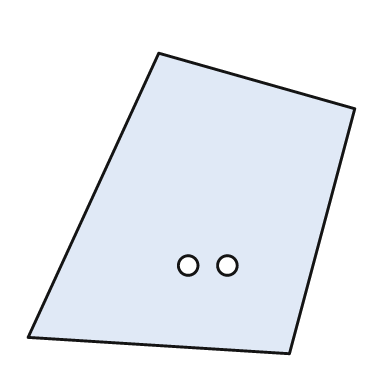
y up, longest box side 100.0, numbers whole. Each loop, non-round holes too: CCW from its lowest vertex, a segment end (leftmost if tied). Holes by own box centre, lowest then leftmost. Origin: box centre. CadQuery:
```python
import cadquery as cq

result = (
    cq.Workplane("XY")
    .moveTo(30.0, -46.0)
    .lineTo(50.0, 29.0)
    .lineTo(-10.0, 46.0)
    .lineTo(-50.0, -41.0)
    .close()
    .moveTo(-1.0, -19.0)
    .circle(3.0)
    .moveTo(11.0, -19.0)
    .circle(3.0)
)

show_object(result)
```